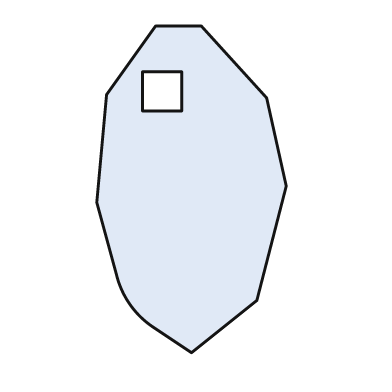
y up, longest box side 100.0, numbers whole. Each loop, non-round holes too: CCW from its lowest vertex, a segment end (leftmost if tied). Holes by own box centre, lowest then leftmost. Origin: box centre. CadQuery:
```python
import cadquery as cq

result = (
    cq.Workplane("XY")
    .moveTo(0.0, -50.0)
    .lineTo(20.0, -34.0)
    .lineTo(29.0, 1.0)
    .lineTo(23.0, 28.0)
    .lineTo(3.0, 50.0)
    .lineTo(-11.0, 50.0)
    .lineTo(-26.0, 29.0)
    .lineTo(-29.0, -4.0)
    .lineTo(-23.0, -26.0)
    .threePointArc((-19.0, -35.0), (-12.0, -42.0))
    .close()
    .moveTo(-15.0, 24.0)
    .lineTo(-3.0, 24.0)
    .lineTo(-3.0, 36.0)
    .lineTo(-15.0, 36.0)
    .close()
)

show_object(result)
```